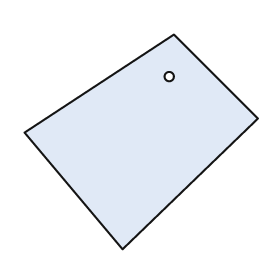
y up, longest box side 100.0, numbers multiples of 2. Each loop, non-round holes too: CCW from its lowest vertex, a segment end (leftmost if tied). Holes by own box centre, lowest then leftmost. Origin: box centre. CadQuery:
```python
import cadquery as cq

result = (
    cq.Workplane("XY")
    .moveTo(-8.0, -46.0)
    .lineTo(50.0, 10.0)
    .lineTo(14.0, 46.0)
    .lineTo(-50.0, 4.0)
    .close()
    .moveTo(12.0, 28.0)
    .circle(2.0)
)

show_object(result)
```